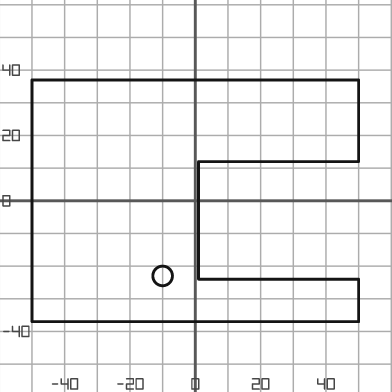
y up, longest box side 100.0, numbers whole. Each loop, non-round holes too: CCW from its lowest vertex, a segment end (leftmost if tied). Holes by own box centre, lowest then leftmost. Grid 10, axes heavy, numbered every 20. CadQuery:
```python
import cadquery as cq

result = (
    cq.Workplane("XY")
    .moveTo(-50.0, -37.0)
    .lineTo(50.0, -37.0)
    .lineTo(50.0, -24.0)
    .lineTo(1.0, -24.0)
    .lineTo(1.0, 12.0)
    .lineTo(50.0, 12.0)
    .lineTo(50.0, 37.0)
    .lineTo(-50.0, 37.0)
    .close()
    .moveTo(-10.0, -23.0)
    .circle(3.0)
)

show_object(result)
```